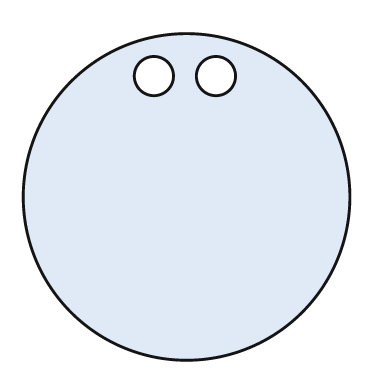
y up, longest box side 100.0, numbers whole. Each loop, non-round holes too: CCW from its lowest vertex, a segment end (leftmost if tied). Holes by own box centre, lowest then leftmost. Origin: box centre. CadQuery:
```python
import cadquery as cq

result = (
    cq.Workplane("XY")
    .moveTo(0.0, 0.0)
    .circle(50.0)
    .moveTo(-10.0, 37.0)
    .circle(6.0)
    .moveTo(9.0, 37.0)
    .circle(6.0)
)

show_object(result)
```